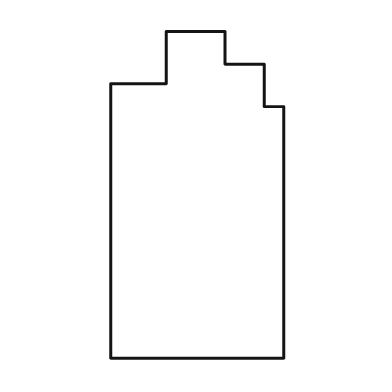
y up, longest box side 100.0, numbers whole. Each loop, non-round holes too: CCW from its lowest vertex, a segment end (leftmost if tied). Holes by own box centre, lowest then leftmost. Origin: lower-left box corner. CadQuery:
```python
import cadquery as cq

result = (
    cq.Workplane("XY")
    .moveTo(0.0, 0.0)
    .lineTo(53.0, 0.0)
    .lineTo(53.0, 77.0)
    .lineTo(47.0, 77.0)
    .lineTo(47.0, 90.0)
    .lineTo(35.0, 90.0)
    .lineTo(35.0, 100.0)
    .lineTo(17.0, 100.0)
    .lineTo(17.0, 84.0)
    .lineTo(0.0, 84.0)
    .close()
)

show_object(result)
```